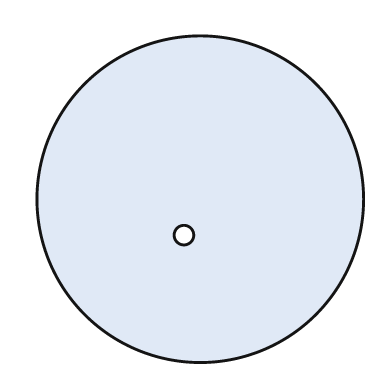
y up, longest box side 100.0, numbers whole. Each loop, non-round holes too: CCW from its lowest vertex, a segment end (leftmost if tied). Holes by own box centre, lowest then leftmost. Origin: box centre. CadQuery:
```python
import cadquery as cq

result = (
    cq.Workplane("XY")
    .moveTo(0.0, 0.0)
    .circle(50.0)
    .moveTo(-5.0, -11.0)
    .circle(3.0)
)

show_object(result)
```